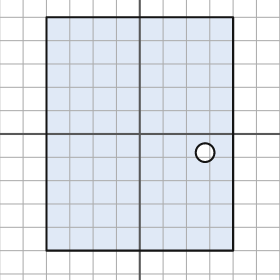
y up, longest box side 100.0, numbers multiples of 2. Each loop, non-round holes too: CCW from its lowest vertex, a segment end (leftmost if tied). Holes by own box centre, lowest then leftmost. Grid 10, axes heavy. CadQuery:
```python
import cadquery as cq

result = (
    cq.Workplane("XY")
    .moveTo(-40.0, -50.0)
    .lineTo(40.0, -50.0)
    .lineTo(40.0, 50.0)
    .lineTo(-40.0, 50.0)
    .close()
    .moveTo(28.0, -8.0)
    .circle(4.0)
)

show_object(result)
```